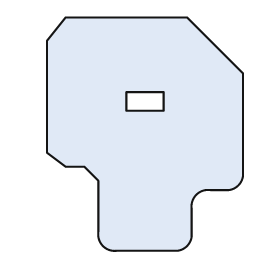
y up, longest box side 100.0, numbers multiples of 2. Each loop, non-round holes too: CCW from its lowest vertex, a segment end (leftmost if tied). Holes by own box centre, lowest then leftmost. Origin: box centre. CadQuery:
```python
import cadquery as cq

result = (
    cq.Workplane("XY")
    .moveTo(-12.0, -50.0)
    .lineTo(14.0, -50.0)
    .threePointArc((18.0, -48.0), (20.0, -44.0))
    .lineTo(20.0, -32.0)
    .threePointArc((22.0, -26.0), (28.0, -24.0))
    .lineTo(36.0, -24.0)
    .threePointArc((40.0, -22.0), (42.0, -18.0))
    .lineTo(42.0, 26.0)
    .lineTo(18.0, 50.0)
    .lineTo(-34.0, 50.0)
    .lineTo(-42.0, 40.0)
    .lineTo(-42.0, -8.0)
    .lineTo(-34.0, -14.0)
    .lineTo(-26.0, -14.0)
    .lineTo(-20.0, -20.0)
    .lineTo(-20.0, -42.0)
    .threePointArc((-18.0, -48.0), (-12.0, -50.0))
    .close()
    .moveTo(-8.0, 10.0)
    .lineTo(8.0, 10.0)
    .lineTo(8.0, 18.0)
    .lineTo(-8.0, 18.0)
    .close()
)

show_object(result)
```